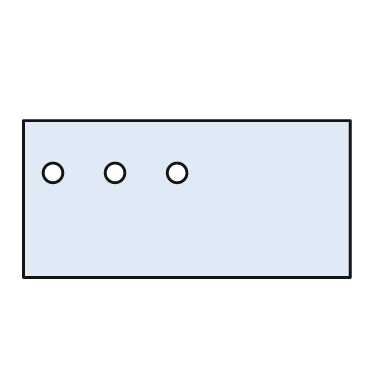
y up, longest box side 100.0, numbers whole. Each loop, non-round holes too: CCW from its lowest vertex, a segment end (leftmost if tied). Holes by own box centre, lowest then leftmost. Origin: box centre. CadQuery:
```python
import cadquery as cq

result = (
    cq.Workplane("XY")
    .moveTo(-50.0, -24.0)
    .lineTo(50.0, -24.0)
    .lineTo(50.0, 24.0)
    .lineTo(-50.0, 24.0)
    .close()
    .moveTo(-41.0, 8.0)
    .circle(3.0)
    .moveTo(-22.0, 8.0)
    .circle(3.0)
    .moveTo(-3.0, 8.0)
    .circle(3.0)
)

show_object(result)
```